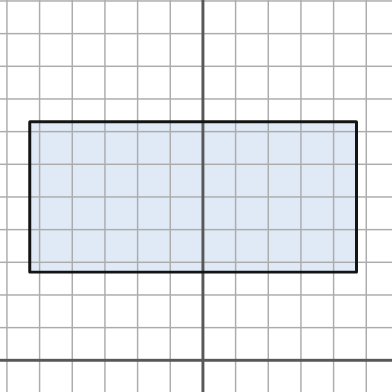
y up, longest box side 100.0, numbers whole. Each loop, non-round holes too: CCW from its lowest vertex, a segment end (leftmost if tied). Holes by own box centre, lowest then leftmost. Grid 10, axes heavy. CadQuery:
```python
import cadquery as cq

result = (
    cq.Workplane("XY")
    .moveTo(-53.0, 27.0)
    .lineTo(47.0, 27.0)
    .lineTo(47.0, 73.0)
    .lineTo(-53.0, 73.0)
    .close()
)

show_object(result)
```